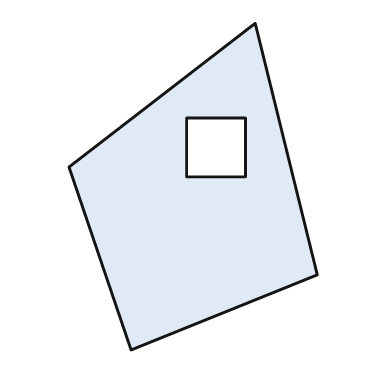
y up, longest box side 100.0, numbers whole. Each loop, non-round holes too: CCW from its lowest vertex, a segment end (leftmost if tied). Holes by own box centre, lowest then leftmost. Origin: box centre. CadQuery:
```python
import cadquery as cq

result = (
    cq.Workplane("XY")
    .moveTo(-19.0, -50.0)
    .lineTo(38.0, -27.0)
    .lineTo(19.0, 50.0)
    .lineTo(-38.0, 6.0)
    .close()
    .moveTo(-2.0, 3.0)
    .lineTo(16.0, 3.0)
    .lineTo(16.0, 21.0)
    .lineTo(-2.0, 21.0)
    .close()
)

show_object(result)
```